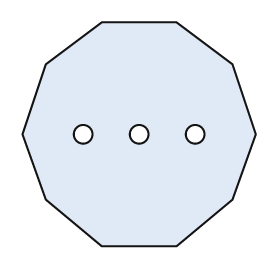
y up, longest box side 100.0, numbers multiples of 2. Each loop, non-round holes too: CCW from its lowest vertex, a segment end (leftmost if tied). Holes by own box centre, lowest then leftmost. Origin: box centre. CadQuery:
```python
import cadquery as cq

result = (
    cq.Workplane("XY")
    .moveTo(-16.0, -48.0)
    .lineTo(16.0, -48.0)
    .lineTo(40.0, -28.0)
    .lineTo(50.0, 0.0)
    .lineTo(40.0, 30.0)
    .lineTo(16.0, 48.0)
    .lineTo(-16.0, 48.0)
    .lineTo(-40.0, 30.0)
    .lineTo(-50.0, 0.0)
    .lineTo(-40.0, -28.0)
    .close()
    .moveTo(-24.0, 0.0)
    .circle(4.0)
    .moveTo(0.0, 0.0)
    .circle(4.0)
    .moveTo(24.0, 0.0)
    .circle(4.0)
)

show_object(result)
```